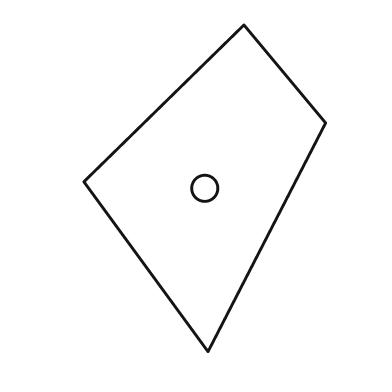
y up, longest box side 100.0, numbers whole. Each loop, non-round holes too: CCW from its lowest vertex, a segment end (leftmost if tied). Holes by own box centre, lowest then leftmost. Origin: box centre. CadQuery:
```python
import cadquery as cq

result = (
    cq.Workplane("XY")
    .moveTo(1.0, -50.0)
    .lineTo(37.0, 20.0)
    .lineTo(12.0, 50.0)
    .lineTo(-37.0, 2.0)
    .close()
    .moveTo(0.0, 0.0)
    .circle(4.0)
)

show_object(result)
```